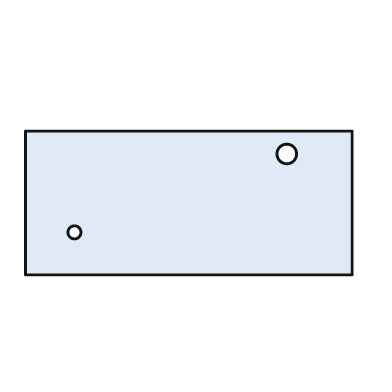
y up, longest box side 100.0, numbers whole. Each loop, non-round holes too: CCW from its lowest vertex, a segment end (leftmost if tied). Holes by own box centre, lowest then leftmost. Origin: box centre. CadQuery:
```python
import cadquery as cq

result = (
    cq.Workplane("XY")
    .moveTo(-50.0, -22.0)
    .lineTo(50.0, -22.0)
    .lineTo(50.0, 22.0)
    .lineTo(-50.0, 22.0)
    .close()
    .moveTo(-35.0, -9.0)
    .circle(2.0)
    .moveTo(30.0, 15.0)
    .circle(3.0)
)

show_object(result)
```